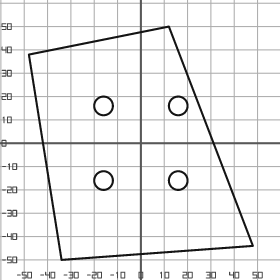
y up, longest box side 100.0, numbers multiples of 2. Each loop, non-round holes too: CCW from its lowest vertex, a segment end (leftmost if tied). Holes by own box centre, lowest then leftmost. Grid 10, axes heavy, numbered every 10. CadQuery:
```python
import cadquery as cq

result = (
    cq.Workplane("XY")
    .moveTo(-34.0, -50.0)
    .lineTo(48.0, -44.0)
    .lineTo(12.0, 50.0)
    .lineTo(-48.0, 38.0)
    .close()
    .moveTo(-16.0, -16.0)
    .circle(4.0)
    .moveTo(16.0, -16.0)
    .circle(4.0)
    .moveTo(-16.0, 16.0)
    .circle(4.0)
    .moveTo(16.0, 16.0)
    .circle(4.0)
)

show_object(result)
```